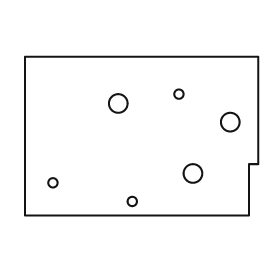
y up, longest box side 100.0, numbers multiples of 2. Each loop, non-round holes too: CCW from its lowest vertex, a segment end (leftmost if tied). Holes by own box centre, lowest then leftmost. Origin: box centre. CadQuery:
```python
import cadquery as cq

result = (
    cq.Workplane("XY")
    .moveTo(-50.0, -34.0)
    .lineTo(46.0, -34.0)
    .lineTo(46.0, -12.0)
    .lineTo(50.0, -12.0)
    .lineTo(50.0, 34.0)
    .lineTo(-50.0, 34.0)
    .close()
    .moveTo(-4.0, -28.0)
    .circle(2.0)
    .moveTo(-38.0, -20.0)
    .circle(2.0)
    .moveTo(22.0, -16.0)
    .circle(4.0)
    .moveTo(38.0, 6.0)
    .circle(4.0)
    .moveTo(-10.0, 14.0)
    .circle(4.0)
    .moveTo(16.0, 18.0)
    .circle(2.0)
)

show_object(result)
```